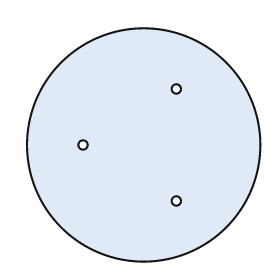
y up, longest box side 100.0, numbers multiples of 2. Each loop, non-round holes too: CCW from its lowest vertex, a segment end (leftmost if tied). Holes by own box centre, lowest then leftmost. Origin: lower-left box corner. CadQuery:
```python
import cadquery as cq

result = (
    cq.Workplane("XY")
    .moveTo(50.0, 50.0)
    .circle(50.0)
    .moveTo(64.0, 26.0)
    .circle(2.0)
    .moveTo(24.0, 50.0)
    .circle(2.0)
    .moveTo(64.0, 74.0)
    .circle(2.0)
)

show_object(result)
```